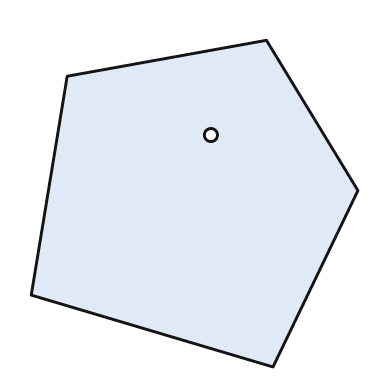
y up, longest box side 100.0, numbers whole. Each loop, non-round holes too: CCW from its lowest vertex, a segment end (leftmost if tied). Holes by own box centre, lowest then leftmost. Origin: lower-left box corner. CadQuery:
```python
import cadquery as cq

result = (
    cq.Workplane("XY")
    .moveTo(74.0, 0.0)
    .lineTo(100.0, 54.0)
    .lineTo(72.0, 100.0)
    .lineTo(11.0, 89.0)
    .lineTo(0.0, 22.0)
    .close()
    .moveTo(55.0, 71.0)
    .circle(2.0)
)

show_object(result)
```